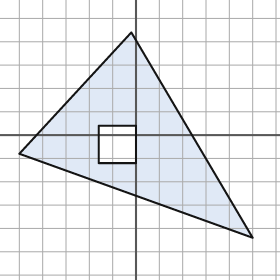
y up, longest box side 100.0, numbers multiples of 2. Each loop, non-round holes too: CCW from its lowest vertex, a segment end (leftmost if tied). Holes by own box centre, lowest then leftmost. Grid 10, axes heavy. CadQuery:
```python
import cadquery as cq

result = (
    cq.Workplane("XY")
    .moveTo(50.0, -44.0)
    .lineTo(-2.0, 44.0)
    .lineTo(-50.0, -8.0)
    .close()
    .moveTo(-16.0, -12.0)
    .lineTo(0.0, -12.0)
    .lineTo(0.0, 4.0)
    .lineTo(-16.0, 4.0)
    .close()
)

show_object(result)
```